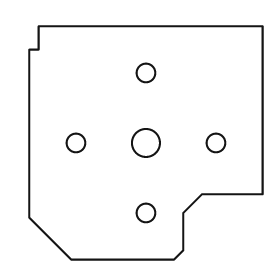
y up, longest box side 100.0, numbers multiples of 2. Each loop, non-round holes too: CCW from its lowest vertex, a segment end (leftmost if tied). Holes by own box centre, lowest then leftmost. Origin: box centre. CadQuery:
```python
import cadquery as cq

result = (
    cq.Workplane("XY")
    .moveTo(-32.0, -50.0)
    .lineTo(12.0, -50.0)
    .lineTo(16.0, -46.0)
    .lineTo(16.0, -30.0)
    .lineTo(24.0, -22.0)
    .lineTo(50.0, -22.0)
    .lineTo(50.0, 50.0)
    .lineTo(-46.0, 50.0)
    .lineTo(-46.0, 40.0)
    .lineTo(-50.0, 40.0)
    .lineTo(-50.0, -32.0)
    .close()
    .moveTo(0.0, -30.0)
    .circle(4.0)
    .moveTo(-30.0, 0.0)
    .circle(4.0)
    .moveTo(0.0, 0.0)
    .circle(6.0)
    .moveTo(30.0, 0.0)
    .circle(4.0)
    .moveTo(0.0, 30.0)
    .circle(4.0)
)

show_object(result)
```